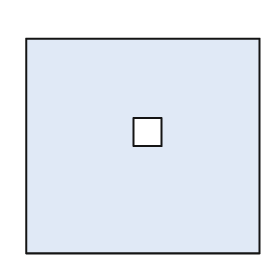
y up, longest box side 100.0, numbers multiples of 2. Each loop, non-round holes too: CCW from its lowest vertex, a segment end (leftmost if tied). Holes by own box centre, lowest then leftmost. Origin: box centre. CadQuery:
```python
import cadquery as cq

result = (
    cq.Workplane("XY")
    .moveTo(-50.0, -46.0)
    .lineTo(50.0, -46.0)
    .lineTo(50.0, 46.0)
    .lineTo(-50.0, 46.0)
    .close()
    .moveTo(-4.0, 0.0)
    .lineTo(8.0, 0.0)
    .lineTo(8.0, 12.0)
    .lineTo(-4.0, 12.0)
    .close()
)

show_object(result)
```